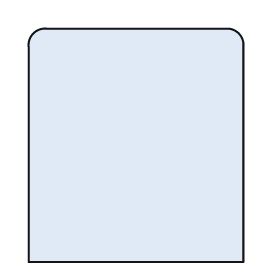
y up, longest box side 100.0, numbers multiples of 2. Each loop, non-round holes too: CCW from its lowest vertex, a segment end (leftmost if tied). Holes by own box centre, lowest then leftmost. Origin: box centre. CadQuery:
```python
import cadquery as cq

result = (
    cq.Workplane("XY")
    .moveTo(-46.0, -50.0)
    .lineTo(46.0, -50.0)
    .lineTo(46.0, 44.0)
    .threePointArc((44.0, 48.0), (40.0, 50.0))
    .lineTo(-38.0, 50.0)
    .threePointArc((-44.0, 48.0), (-46.0, 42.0))
    .close()
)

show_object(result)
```